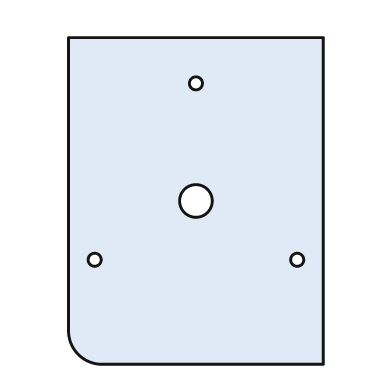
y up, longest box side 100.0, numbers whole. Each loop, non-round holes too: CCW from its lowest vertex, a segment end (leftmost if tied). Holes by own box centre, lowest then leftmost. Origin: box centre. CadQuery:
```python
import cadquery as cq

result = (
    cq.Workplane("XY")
    .moveTo(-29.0, -50.0)
    .lineTo(39.0, -50.0)
    .lineTo(39.0, 50.0)
    .lineTo(-39.0, 50.0)
    .lineTo(-39.0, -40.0)
    .threePointArc((-36.0, -47.0), (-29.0, -50.0))
    .close()
    .moveTo(-31.0, -18.0)
    .circle(2.0)
    .moveTo(31.0, -18.0)
    .circle(2.0)
    .moveTo(0.0, 0.0)
    .circle(5.0)
    .moveTo(0.0, 36.0)
    .circle(2.0)
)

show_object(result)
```